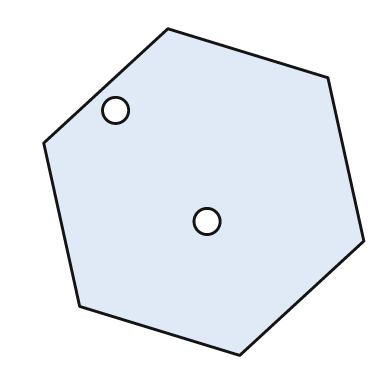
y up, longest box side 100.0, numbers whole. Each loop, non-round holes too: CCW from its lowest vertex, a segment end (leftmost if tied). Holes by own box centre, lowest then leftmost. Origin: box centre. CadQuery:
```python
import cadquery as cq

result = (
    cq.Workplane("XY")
    .moveTo(11.0, -50.0)
    .lineTo(49.0, -15.0)
    .lineTo(38.0, 35.0)
    .lineTo(-11.0, 50.0)
    .lineTo(-49.0, 15.0)
    .lineTo(-38.0, -35.0)
    .close()
    .moveTo(1.0, -9.0)
    .circle(4.0)
    .moveTo(-27.0, 25.0)
    .circle(4.0)
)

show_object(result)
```